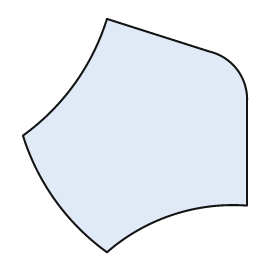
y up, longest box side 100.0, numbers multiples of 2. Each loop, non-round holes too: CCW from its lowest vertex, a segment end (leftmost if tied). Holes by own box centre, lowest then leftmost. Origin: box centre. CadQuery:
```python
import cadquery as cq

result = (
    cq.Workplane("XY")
    .moveTo(-12.0, -50.0)
    .threePointArc((16.0, -34.0), (48.0, -30.0))
    .lineTo(48.0, 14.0)
    .threePointArc((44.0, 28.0), (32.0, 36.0))
    .lineTo(-12.0, 50.0)
    .threePointArc((-26.0, 22.0), (-48.0, 0.0))
    .threePointArc((-34.0, -28.0), (-12.0, -50.0))
    .close()
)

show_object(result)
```